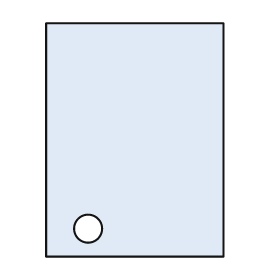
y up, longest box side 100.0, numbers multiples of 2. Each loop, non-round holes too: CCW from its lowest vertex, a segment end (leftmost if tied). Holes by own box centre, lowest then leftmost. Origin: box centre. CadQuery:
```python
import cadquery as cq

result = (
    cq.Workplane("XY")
    .moveTo(-38.0, -50.0)
    .lineTo(38.0, -50.0)
    .lineTo(38.0, 50.0)
    .lineTo(-38.0, 50.0)
    .close()
    .moveTo(-20.0, -38.0)
    .circle(6.0)
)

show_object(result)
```